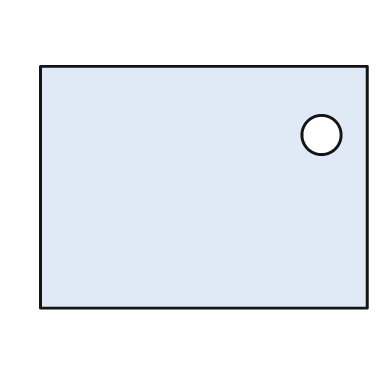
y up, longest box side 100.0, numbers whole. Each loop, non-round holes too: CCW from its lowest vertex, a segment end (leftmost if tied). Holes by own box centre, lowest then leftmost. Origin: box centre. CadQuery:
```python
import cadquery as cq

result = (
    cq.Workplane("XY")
    .moveTo(-50.0, -37.0)
    .lineTo(50.0, -37.0)
    .lineTo(50.0, 37.0)
    .lineTo(-50.0, 37.0)
    .close()
    .moveTo(36.0, 16.0)
    .circle(6.0)
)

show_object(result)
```